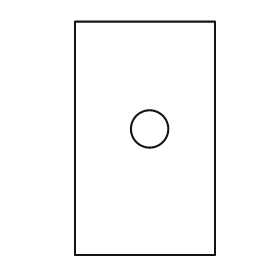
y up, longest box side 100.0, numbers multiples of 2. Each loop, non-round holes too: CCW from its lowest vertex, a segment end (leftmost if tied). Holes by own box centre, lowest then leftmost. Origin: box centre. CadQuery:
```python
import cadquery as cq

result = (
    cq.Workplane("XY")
    .moveTo(-30.0, -50.0)
    .lineTo(30.0, -50.0)
    .lineTo(30.0, 50.0)
    .lineTo(-30.0, 50.0)
    .close()
    .moveTo(2.0, 4.0)
    .circle(8.0)
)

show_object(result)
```